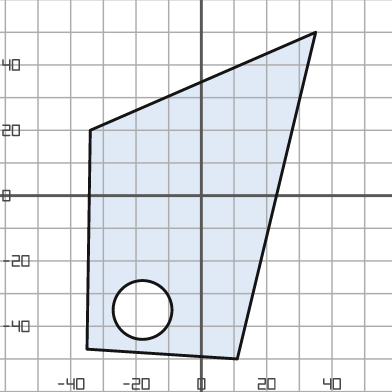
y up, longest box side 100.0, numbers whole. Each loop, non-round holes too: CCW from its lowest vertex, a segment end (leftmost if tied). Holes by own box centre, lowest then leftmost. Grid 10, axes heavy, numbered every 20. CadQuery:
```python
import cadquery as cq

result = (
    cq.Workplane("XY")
    .moveTo(11.0, -50.0)
    .lineTo(35.0, 50.0)
    .lineTo(-34.0, 20.0)
    .lineTo(-35.0, -47.0)
    .close()
    .moveTo(-18.0, -35.0)
    .circle(9.0)
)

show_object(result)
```